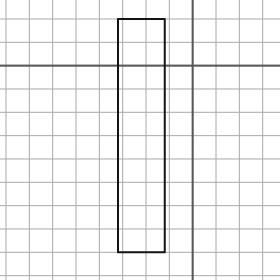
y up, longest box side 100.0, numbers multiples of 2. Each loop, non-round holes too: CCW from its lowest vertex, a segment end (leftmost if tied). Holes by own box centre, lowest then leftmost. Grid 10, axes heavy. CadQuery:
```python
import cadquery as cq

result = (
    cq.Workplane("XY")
    .moveTo(-32.0, -80.0)
    .lineTo(-12.0, -80.0)
    .lineTo(-12.0, 20.0)
    .lineTo(-32.0, 20.0)
    .close()
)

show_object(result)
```